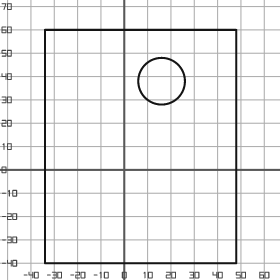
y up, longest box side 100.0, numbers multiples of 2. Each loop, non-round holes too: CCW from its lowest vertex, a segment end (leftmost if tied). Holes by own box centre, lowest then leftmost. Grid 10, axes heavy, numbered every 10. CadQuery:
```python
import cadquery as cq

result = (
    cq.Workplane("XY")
    .moveTo(-34.0, -40.0)
    .lineTo(48.0, -40.0)
    .lineTo(48.0, 60.0)
    .lineTo(-34.0, 60.0)
    .close()
    .moveTo(16.0, 38.0)
    .circle(10.0)
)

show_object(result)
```